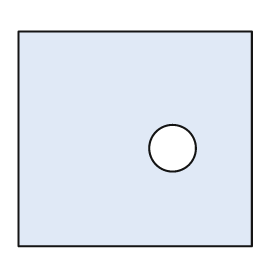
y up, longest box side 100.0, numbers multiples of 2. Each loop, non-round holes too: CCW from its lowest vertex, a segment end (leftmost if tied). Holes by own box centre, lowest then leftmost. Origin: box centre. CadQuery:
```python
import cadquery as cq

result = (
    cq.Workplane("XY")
    .moveTo(-50.0, -46.0)
    .lineTo(50.0, -46.0)
    .lineTo(50.0, 46.0)
    .lineTo(-50.0, 46.0)
    .close()
    .moveTo(16.0, -4.0)
    .circle(10.0)
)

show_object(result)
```